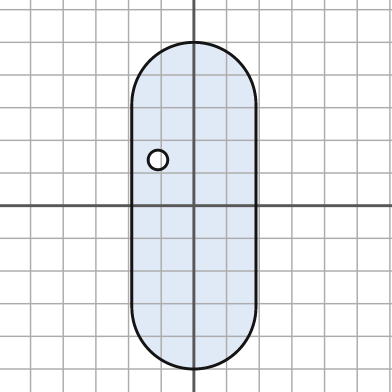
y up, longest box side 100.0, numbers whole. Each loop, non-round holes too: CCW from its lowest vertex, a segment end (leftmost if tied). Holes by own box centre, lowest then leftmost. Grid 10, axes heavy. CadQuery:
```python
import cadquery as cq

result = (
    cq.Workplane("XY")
    .moveTo(-19.0, -31.0)
    .threePointArc((0.0, -50.0), (19.0, -31.0))
    .lineTo(19.0, 31.0)
    .threePointArc((0.0, 50.0), (-19.0, 31.0))
    .close()
    .moveTo(-11.0, 14.0)
    .circle(3.0)
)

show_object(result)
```